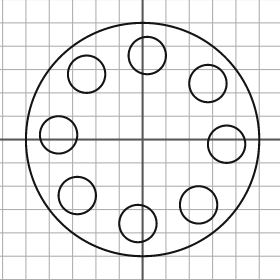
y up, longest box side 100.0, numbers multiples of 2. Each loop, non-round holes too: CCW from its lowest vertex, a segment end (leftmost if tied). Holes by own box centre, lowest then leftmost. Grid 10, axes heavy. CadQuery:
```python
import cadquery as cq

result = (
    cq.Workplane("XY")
    .moveTo(0.0, 0.0)
    .circle(50.0)
    .moveTo(-2.0, -36.0)
    .circle(8.0)
    .moveTo(24.0, -28.0)
    .circle(8.0)
    .moveTo(-28.0, -24.0)
    .circle(8.0)
    .moveTo(36.0, -2.0)
    .circle(8.0)
    .moveTo(-36.0, 2.0)
    .circle(8.0)
    .moveTo(28.0, 24.0)
    .circle(8.0)
    .moveTo(-24.0, 28.0)
    .circle(8.0)
    .moveTo(2.0, 36.0)
    .circle(8.0)
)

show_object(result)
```